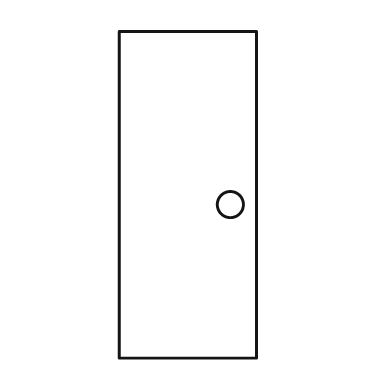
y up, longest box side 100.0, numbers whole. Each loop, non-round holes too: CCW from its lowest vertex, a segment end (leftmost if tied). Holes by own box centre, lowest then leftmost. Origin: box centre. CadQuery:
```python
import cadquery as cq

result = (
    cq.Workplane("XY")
    .moveTo(-21.0, -50.0)
    .lineTo(21.0, -50.0)
    .lineTo(21.0, 50.0)
    .lineTo(-21.0, 50.0)
    .close()
    .moveTo(13.0, -3.0)
    .circle(4.0)
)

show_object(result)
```